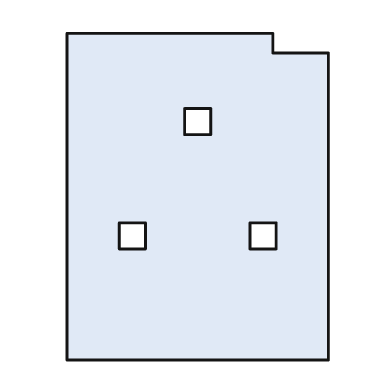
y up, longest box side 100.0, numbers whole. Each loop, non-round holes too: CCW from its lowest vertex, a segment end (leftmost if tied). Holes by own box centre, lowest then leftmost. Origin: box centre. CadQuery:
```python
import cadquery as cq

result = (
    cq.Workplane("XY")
    .moveTo(-40.0, -50.0)
    .lineTo(40.0, -50.0)
    .lineTo(40.0, 44.0)
    .lineTo(23.0, 44.0)
    .lineTo(23.0, 50.0)
    .lineTo(-40.0, 50.0)
    .close()
    .moveTo(-24.0, -16.0)
    .lineTo(-16.0, -16.0)
    .lineTo(-16.0, -8.0)
    .lineTo(-24.0, -8.0)
    .close()
    .moveTo(16.0, -16.0)
    .lineTo(24.0, -16.0)
    .lineTo(24.0, -8.0)
    .lineTo(16.0, -8.0)
    .close()
    .moveTo(-4.0, 19.0)
    .lineTo(4.0, 19.0)
    .lineTo(4.0, 27.0)
    .lineTo(-4.0, 27.0)
    .close()
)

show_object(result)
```